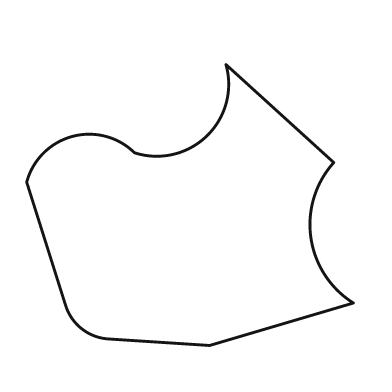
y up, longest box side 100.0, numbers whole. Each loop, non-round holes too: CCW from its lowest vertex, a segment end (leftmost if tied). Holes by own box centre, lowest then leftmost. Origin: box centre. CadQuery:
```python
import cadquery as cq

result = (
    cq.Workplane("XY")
    .moveTo(6.0, -43.0)
    .lineTo(50.0, -30.0)
    .threePointArc((37.0, -10.0), (44.0, 13.0))
    .lineTo(11.0, 43.0)
    .threePointArc((5.0, 21.0), (-17.0, 16.0))
    .threePointArc((-36.0, 21.0), (-50.0, 7.0))
    .lineTo(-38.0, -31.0)
    .threePointArc((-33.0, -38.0), (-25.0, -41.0))
    .close()
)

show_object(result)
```